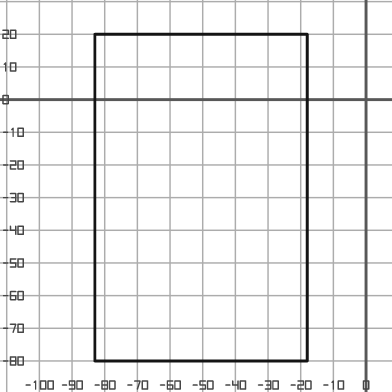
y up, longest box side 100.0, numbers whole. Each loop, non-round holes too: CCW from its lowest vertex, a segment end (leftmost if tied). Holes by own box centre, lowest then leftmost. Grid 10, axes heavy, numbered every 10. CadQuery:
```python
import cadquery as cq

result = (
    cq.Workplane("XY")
    .moveTo(-83.0, -80.0)
    .lineTo(-18.0, -80.0)
    .lineTo(-18.0, 20.0)
    .lineTo(-83.0, 20.0)
    .close()
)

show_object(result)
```